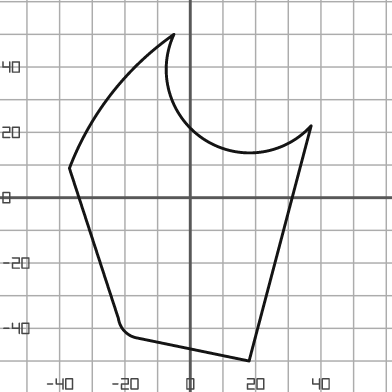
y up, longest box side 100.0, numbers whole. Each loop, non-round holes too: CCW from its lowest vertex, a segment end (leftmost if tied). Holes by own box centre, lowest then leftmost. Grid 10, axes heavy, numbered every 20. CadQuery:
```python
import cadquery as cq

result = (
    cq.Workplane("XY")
    .moveTo(18.0, -50.0)
    .lineTo(37.0, 22.0)
    .threePointArc((4.0, 18.0), (-5.0, 50.0))
    .threePointArc((-24.0, 32.0), (-37.0, 9.0))
    .lineTo(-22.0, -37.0)
    .threePointArc((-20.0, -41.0), (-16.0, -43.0))
    .close()
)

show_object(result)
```